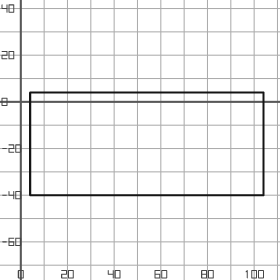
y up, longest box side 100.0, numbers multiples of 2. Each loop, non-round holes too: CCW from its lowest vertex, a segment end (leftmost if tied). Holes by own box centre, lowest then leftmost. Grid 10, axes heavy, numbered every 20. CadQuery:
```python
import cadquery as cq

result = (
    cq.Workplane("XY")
    .moveTo(4.0, -40.0)
    .lineTo(104.0, -40.0)
    .lineTo(104.0, 4.0)
    .lineTo(4.0, 4.0)
    .close()
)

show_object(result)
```